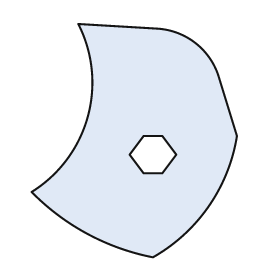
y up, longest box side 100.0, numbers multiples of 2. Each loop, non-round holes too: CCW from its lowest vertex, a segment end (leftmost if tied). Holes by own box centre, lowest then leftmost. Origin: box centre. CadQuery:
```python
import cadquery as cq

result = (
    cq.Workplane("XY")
    .moveTo(8.0, -50.0)
    .threePointArc((32.0, -28.0), (44.0, 2.0))
    .lineTo(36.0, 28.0)
    .threePointArc((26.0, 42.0), (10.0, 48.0))
    .lineTo(-24.0, 50.0)
    .threePointArc((-20.0, 10.0), (-44.0, -22.0))
    .threePointArc((-20.0, -40.0), (8.0, -50.0))
    .close()
    .moveTo(4.0, -14.0)
    .lineTo(12.0, -14.0)
    .lineTo(18.0, -6.0)
    .lineTo(12.0, 2.0)
    .lineTo(4.0, 2.0)
    .lineTo(-2.0, -6.0)
    .close()
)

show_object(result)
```